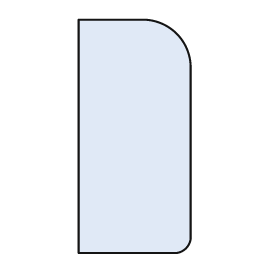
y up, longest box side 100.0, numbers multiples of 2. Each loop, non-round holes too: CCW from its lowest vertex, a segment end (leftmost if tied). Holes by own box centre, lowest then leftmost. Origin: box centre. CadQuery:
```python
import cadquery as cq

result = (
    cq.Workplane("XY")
    .moveTo(-24.0, -50.0)
    .lineTo(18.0, -50.0)
    .threePointArc((22.0, -48.0), (24.0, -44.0))
    .lineTo(24.0, 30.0)
    .threePointArc((18.0, 44.0), (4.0, 50.0))
    .lineTo(-24.0, 50.0)
    .close()
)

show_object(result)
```